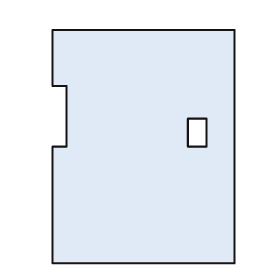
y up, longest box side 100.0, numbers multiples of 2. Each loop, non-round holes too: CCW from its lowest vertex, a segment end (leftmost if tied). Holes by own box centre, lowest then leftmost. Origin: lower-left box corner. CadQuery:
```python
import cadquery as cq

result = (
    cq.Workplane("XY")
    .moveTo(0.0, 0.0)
    .lineTo(78.0, 0.0)
    .lineTo(78.0, 100.0)
    .lineTo(0.0, 100.0)
    .lineTo(0.0, 76.0)
    .lineTo(6.0, 76.0)
    .lineTo(6.0, 50.0)
    .lineTo(0.0, 50.0)
    .close()
    .moveTo(58.0, 50.0)
    .lineTo(66.0, 50.0)
    .lineTo(66.0, 62.0)
    .lineTo(58.0, 62.0)
    .close()
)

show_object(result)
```